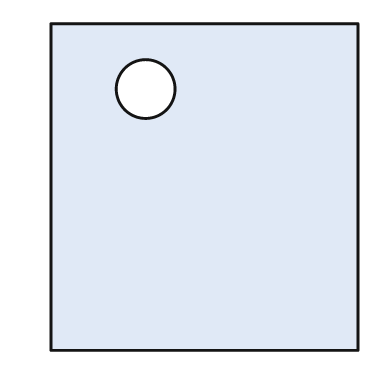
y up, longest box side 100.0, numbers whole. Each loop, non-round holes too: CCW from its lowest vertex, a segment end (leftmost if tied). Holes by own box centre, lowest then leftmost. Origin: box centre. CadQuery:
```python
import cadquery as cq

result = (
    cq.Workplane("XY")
    .moveTo(-47.0, -50.0)
    .lineTo(47.0, -50.0)
    .lineTo(47.0, 50.0)
    .lineTo(-47.0, 50.0)
    .close()
    .moveTo(-18.0, 30.0)
    .circle(9.0)
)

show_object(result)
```